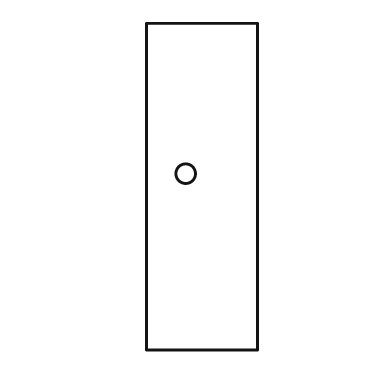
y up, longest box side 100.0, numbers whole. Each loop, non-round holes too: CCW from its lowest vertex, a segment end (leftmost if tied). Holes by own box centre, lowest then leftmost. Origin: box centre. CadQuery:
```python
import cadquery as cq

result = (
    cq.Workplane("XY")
    .moveTo(-17.0, -50.0)
    .lineTo(17.0, -50.0)
    .lineTo(17.0, 50.0)
    .lineTo(-17.0, 50.0)
    .close()
    .moveTo(-5.0, 4.0)
    .circle(3.0)
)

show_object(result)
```